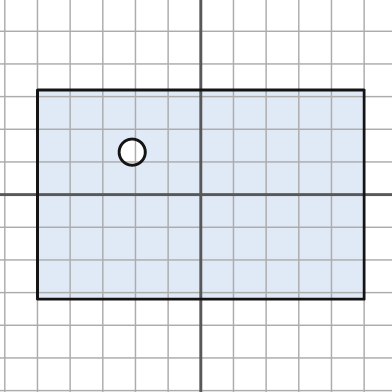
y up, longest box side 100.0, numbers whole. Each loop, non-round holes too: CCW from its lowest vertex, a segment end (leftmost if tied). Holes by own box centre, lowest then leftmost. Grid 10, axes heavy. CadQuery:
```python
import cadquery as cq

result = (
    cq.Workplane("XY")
    .moveTo(-50.0, -32.0)
    .lineTo(50.0, -32.0)
    .lineTo(50.0, 32.0)
    .lineTo(-50.0, 32.0)
    .close()
    .moveTo(-21.0, 13.0)
    .circle(4.0)
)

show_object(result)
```